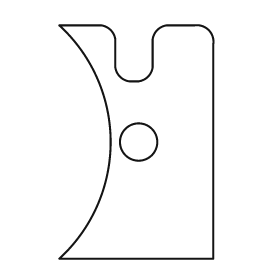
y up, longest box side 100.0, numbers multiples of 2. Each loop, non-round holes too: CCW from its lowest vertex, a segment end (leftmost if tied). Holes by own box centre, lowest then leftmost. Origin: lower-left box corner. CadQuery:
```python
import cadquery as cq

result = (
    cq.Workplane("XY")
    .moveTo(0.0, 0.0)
    .lineTo(66.0, 0.0)
    .lineTo(66.0, 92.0)
    .threePointArc((64.0, 98.0), (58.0, 100.0))
    .lineTo(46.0, 100.0)
    .threePointArc((42.0, 98.0), (40.0, 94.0))
    .lineTo(40.0, 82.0)
    .threePointArc((38.0, 78.0), (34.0, 76.0))
    .lineTo(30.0, 76.0)
    .threePointArc((26.0, 78.0), (24.0, 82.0))
    .lineTo(24.0, 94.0)
    .threePointArc((22.0, 98.0), (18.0, 100.0))
    .lineTo(0.0, 100.0)
    .threePointArc((22.0, 50.0), (0.0, 0.0))
    .close()
    .moveTo(34.0, 50.0)
    .circle(8.0)
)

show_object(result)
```